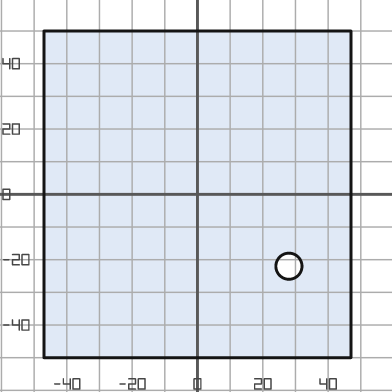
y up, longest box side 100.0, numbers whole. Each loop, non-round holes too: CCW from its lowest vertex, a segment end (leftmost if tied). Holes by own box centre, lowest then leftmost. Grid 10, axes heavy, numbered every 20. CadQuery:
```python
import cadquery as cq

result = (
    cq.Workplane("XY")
    .moveTo(-47.0, -50.0)
    .lineTo(47.0, -50.0)
    .lineTo(47.0, 50.0)
    .lineTo(-47.0, 50.0)
    .close()
    .moveTo(28.0, -22.0)
    .circle(4.0)
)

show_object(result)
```